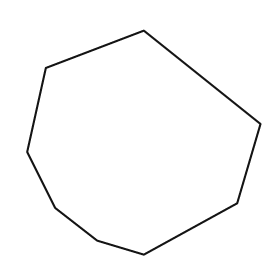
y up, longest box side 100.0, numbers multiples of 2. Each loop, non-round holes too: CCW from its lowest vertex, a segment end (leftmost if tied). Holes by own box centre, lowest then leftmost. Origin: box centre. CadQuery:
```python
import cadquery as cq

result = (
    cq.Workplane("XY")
    .moveTo(0.0, -48.0)
    .lineTo(40.0, -26.0)
    .lineTo(50.0, 8.0)
    .lineTo(0.0, 48.0)
    .lineTo(-42.0, 32.0)
    .lineTo(-50.0, -4.0)
    .lineTo(-38.0, -28.0)
    .lineTo(-20.0, -42.0)
    .close()
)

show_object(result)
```